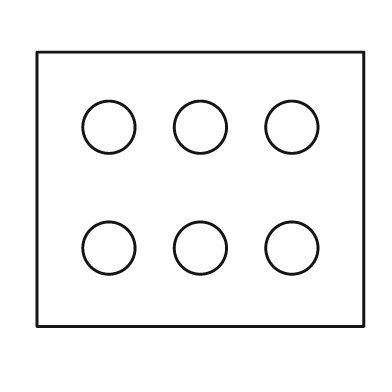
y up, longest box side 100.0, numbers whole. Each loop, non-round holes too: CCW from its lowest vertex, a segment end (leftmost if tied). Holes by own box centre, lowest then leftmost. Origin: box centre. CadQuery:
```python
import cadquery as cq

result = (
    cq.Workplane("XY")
    .moveTo(-50.0, -42.0)
    .lineTo(50.0, -42.0)
    .lineTo(50.0, 42.0)
    .lineTo(-50.0, 42.0)
    .close()
    .moveTo(-28.0, -18.0)
    .circle(8.0)
    .moveTo(0.0, -18.0)
    .circle(8.0)
    .moveTo(28.0, -18.0)
    .circle(8.0)
    .moveTo(-28.0, 19.0)
    .circle(8.0)
    .moveTo(0.0, 19.0)
    .circle(8.0)
    .moveTo(28.0, 19.0)
    .circle(8.0)
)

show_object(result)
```